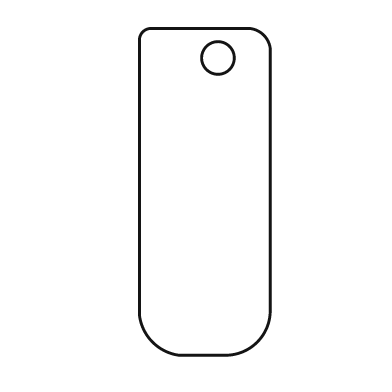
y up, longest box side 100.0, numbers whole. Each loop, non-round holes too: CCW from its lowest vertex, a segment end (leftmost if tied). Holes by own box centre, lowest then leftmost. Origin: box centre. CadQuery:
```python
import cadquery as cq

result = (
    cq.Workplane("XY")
    .moveTo(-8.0, -50.0)
    .lineTo(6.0, -50.0)
    .threePointArc((16.0, -46.0), (20.0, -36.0))
    .lineTo(20.0, 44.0)
    .threePointArc((18.0, 48.0), (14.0, 50.0))
    .lineTo(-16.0, 50.0)
    .threePointArc((-19.0, 49.0), (-20.0, 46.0))
    .lineTo(-20.0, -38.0)
    .threePointArc((-16.0, -46.0), (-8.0, -50.0))
    .close()
    .moveTo(4.0, 41.0)
    .circle(5.0)
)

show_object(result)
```